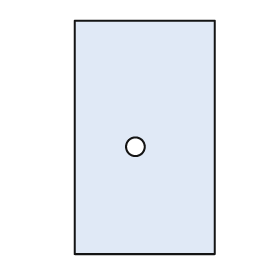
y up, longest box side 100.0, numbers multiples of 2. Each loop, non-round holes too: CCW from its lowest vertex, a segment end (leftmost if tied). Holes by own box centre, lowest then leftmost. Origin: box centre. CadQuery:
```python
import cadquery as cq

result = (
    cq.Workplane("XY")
    .moveTo(-30.0, -50.0)
    .lineTo(30.0, -50.0)
    .lineTo(30.0, 50.0)
    .lineTo(-30.0, 50.0)
    .close()
    .moveTo(-4.0, -4.0)
    .circle(4.0)
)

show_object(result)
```